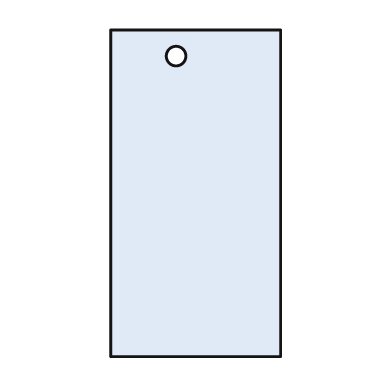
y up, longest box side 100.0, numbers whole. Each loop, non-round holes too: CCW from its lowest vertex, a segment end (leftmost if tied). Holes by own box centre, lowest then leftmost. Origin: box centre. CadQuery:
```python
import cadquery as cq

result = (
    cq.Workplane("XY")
    .moveTo(-26.0, -50.0)
    .lineTo(26.0, -50.0)
    .lineTo(26.0, 50.0)
    .lineTo(-26.0, 50.0)
    .close()
    .moveTo(-6.0, 42.0)
    .circle(3.0)
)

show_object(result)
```